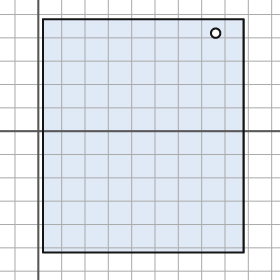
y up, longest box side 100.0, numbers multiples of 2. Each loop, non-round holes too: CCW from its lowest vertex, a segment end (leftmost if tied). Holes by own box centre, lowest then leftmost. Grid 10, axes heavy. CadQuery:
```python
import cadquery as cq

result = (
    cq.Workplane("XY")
    .moveTo(2.0, -52.0)
    .lineTo(88.0, -52.0)
    .lineTo(88.0, 48.0)
    .lineTo(2.0, 48.0)
    .close()
    .moveTo(76.0, 42.0)
    .circle(2.0)
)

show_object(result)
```